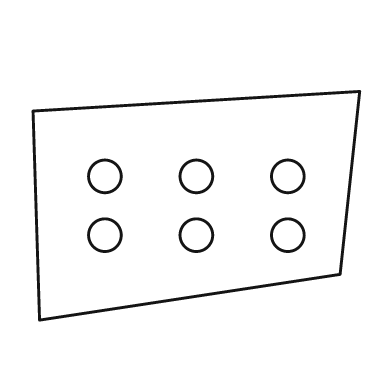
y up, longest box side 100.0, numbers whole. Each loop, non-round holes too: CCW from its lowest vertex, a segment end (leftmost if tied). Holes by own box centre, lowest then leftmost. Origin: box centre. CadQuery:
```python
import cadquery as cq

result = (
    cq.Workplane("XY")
    .moveTo(-48.0, -35.0)
    .lineTo(44.0, -21.0)
    .lineTo(50.0, 35.0)
    .lineTo(-50.0, 29.0)
    .close()
    .moveTo(-28.0, -9.0)
    .circle(5.0)
    .moveTo(0.0, -9.0)
    .circle(5.0)
    .moveTo(28.0, -9.0)
    .circle(5.0)
    .moveTo(-28.0, 9.0)
    .circle(5.0)
    .moveTo(0.0, 9.0)
    .circle(5.0)
    .moveTo(28.0, 9.0)
    .circle(5.0)
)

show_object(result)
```